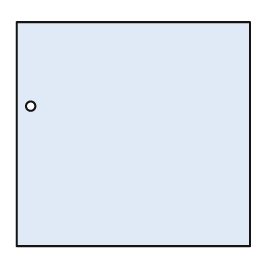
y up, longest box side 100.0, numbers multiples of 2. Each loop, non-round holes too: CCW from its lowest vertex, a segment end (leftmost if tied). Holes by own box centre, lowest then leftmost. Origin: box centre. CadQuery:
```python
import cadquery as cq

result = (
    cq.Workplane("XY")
    .moveTo(-50.0, -48.0)
    .lineTo(50.0, -48.0)
    .lineTo(50.0, 48.0)
    .lineTo(-50.0, 48.0)
    .close()
    .moveTo(-44.0, 12.0)
    .circle(2.0)
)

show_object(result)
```